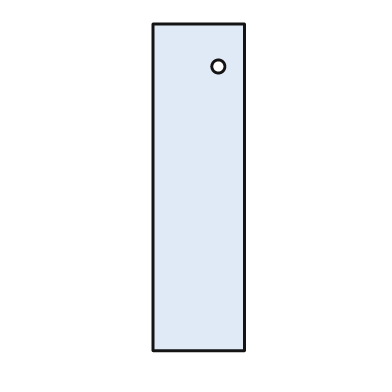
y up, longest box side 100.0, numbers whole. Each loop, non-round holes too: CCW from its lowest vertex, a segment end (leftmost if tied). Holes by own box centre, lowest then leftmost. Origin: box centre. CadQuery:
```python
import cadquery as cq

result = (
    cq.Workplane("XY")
    .moveTo(-14.0, -50.0)
    .lineTo(14.0, -50.0)
    .lineTo(14.0, 50.0)
    .lineTo(-14.0, 50.0)
    .close()
    .moveTo(6.0, 37.0)
    .circle(2.0)
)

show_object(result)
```